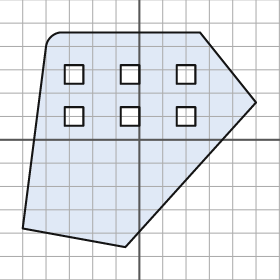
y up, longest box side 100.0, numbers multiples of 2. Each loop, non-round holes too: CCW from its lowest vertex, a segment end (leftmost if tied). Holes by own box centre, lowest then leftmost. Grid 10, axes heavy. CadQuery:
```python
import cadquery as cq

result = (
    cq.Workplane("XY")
    .moveTo(-6.0, -46.0)
    .lineTo(50.0, 16.0)
    .lineTo(26.0, 46.0)
    .lineTo(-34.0, 46.0)
    .threePointArc((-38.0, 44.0), (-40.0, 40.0))
    .lineTo(-50.0, -38.0)
    .close()
    .moveTo(-32.0, 6.0)
    .lineTo(-24.0, 6.0)
    .lineTo(-24.0, 14.0)
    .lineTo(-32.0, 14.0)
    .close()
    .moveTo(-8.0, 6.0)
    .lineTo(0.0, 6.0)
    .lineTo(0.0, 14.0)
    .lineTo(-8.0, 14.0)
    .close()
    .moveTo(16.0, 6.0)
    .lineTo(24.0, 6.0)
    .lineTo(24.0, 14.0)
    .lineTo(16.0, 14.0)
    .close()
    .moveTo(-32.0, 24.0)
    .lineTo(-24.0, 24.0)
    .lineTo(-24.0, 32.0)
    .lineTo(-32.0, 32.0)
    .close()
    .moveTo(-8.0, 24.0)
    .lineTo(0.0, 24.0)
    .lineTo(0.0, 32.0)
    .lineTo(-8.0, 32.0)
    .close()
    .moveTo(16.0, 24.0)
    .lineTo(24.0, 24.0)
    .lineTo(24.0, 32.0)
    .lineTo(16.0, 32.0)
    .close()
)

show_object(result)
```